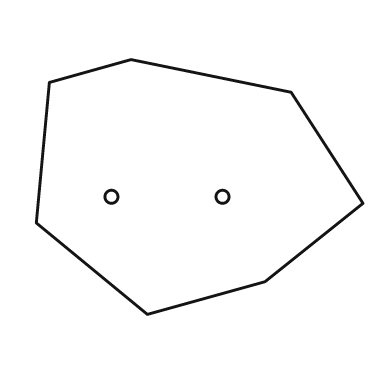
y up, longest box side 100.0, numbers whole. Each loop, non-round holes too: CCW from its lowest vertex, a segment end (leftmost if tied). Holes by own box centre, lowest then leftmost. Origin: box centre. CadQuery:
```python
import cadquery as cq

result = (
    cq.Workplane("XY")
    .moveTo(-16.0, -39.0)
    .lineTo(20.0, -29.0)
    .lineTo(50.0, -5.0)
    .lineTo(28.0, 29.0)
    .lineTo(-21.0, 39.0)
    .lineTo(-46.0, 32.0)
    .lineTo(-50.0, -11.0)
    .close()
    .moveTo(-27.0, -3.0)
    .circle(2.0)
    .moveTo(7.0, -3.0)
    .circle(2.0)
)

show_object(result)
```